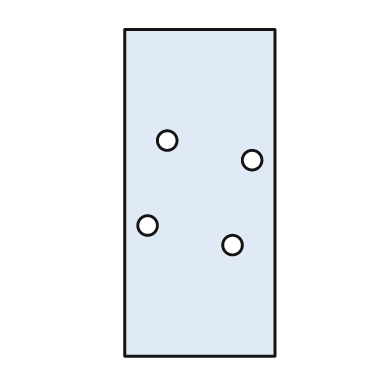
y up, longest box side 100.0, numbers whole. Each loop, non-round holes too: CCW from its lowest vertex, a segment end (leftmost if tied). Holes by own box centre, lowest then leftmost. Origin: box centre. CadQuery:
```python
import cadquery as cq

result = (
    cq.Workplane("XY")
    .moveTo(-23.0, -50.0)
    .lineTo(23.0, -50.0)
    .lineTo(23.0, 50.0)
    .lineTo(-23.0, 50.0)
    .close()
    .moveTo(10.0, -16.0)
    .circle(3.0)
    .moveTo(-16.0, -10.0)
    .circle(3.0)
    .moveTo(16.0, 10.0)
    .circle(3.0)
    .moveTo(-10.0, 16.0)
    .circle(3.0)
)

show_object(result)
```